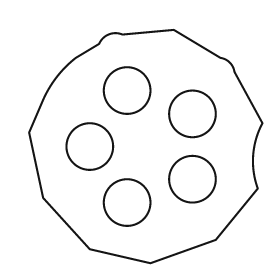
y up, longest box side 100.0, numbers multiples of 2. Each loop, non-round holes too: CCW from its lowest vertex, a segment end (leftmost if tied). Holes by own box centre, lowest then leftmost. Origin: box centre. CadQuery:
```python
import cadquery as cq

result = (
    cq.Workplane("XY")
    .moveTo(2.0, -50.0)
    .lineTo(30.0, -40.0)
    .lineTo(48.0, -18.0)
    .threePointArc((46.0, -4.0), (50.0, 10.0))
    .lineTo(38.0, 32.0)
    .threePointArc((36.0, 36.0), (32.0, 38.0))
    .lineTo(12.0, 50.0)
    .lineTo(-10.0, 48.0)
    .threePointArc((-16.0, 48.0), (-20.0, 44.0))
    .lineTo(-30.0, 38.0)
    .threePointArc((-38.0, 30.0), (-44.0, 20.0))
    .lineTo(-50.0, 6.0)
    .lineTo(-44.0, -22.0)
    .lineTo(-24.0, -44.0)
    .close()
    .moveTo(-8.0, -24.0)
    .circle(10.0)
    .moveTo(20.0, -14.0)
    .circle(10.0)
    .moveTo(-24.0, 0.0)
    .circle(10.0)
    .moveTo(20.0, 14.0)
    .circle(10.0)
    .moveTo(-8.0, 24.0)
    .circle(10.0)
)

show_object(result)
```